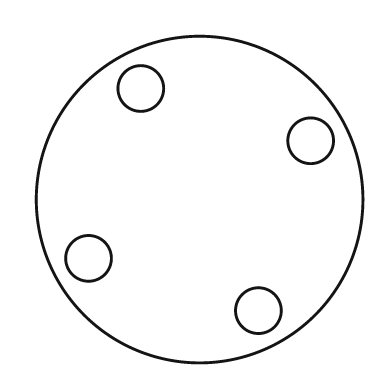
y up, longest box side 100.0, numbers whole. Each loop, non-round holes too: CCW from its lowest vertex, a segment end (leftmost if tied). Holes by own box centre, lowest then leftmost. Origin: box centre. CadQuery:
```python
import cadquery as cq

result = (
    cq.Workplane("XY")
    .moveTo(0.0, 0.0)
    .circle(50.0)
    .moveTo(18.0, -34.0)
    .circle(7.0)
    .moveTo(-34.0, -18.0)
    .circle(7.0)
    .moveTo(34.0, 18.0)
    .circle(7.0)
    .moveTo(-18.0, 34.0)
    .circle(7.0)
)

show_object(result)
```